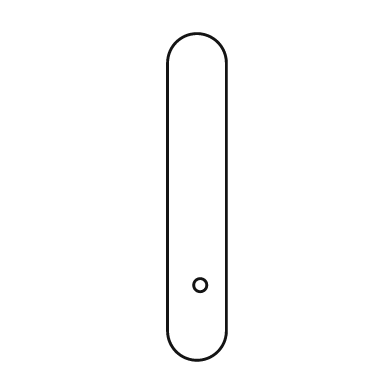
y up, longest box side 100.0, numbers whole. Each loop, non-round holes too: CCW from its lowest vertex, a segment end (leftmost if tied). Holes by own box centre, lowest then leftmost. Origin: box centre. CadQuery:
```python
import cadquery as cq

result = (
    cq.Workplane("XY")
    .moveTo(-9.0, -41.0)
    .threePointArc((0.0, -50.0), (9.0, -41.0))
    .lineTo(9.0, 41.0)
    .threePointArc((0.0, 50.0), (-9.0, 41.0))
    .close()
    .moveTo(1.0, -27.0)
    .circle(2.0)
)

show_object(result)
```